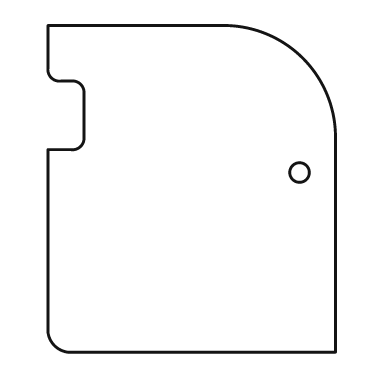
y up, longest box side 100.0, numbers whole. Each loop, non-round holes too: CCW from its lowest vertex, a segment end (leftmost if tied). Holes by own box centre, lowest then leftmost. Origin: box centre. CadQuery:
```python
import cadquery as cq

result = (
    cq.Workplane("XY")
    .moveTo(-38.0, -50.0)
    .lineTo(44.0, -50.0)
    .lineTo(44.0, 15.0)
    .threePointArc((34.0, 40.0), (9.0, 50.0))
    .lineTo(-44.0, 50.0)
    .lineTo(-44.0, 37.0)
    .threePointArc((-43.0, 34.0), (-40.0, 33.0))
    .lineTo(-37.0, 33.0)
    .threePointArc((-34.0, 32.0), (-33.0, 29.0))
    .lineTo(-33.0, 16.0)
    .threePointArc((-34.0, 13.0), (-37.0, 12.0))
    .lineTo(-44.0, 12.0)
    .lineTo(-44.0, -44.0)
    .threePointArc((-42.0, -48.0), (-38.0, -50.0))
    .close()
    .moveTo(33.0, 5.0)
    .circle(3.0)
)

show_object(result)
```